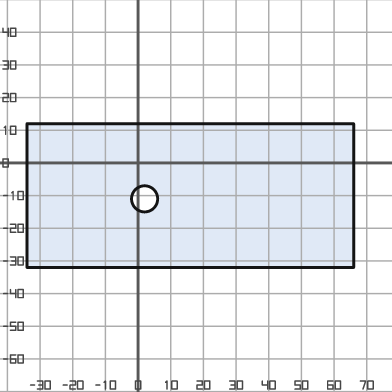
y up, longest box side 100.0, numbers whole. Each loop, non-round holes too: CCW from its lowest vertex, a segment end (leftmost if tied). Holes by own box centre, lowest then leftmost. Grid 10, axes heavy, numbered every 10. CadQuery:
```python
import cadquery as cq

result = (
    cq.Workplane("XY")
    .moveTo(-34.0, -32.0)
    .lineTo(66.0, -32.0)
    .lineTo(66.0, 12.0)
    .lineTo(-34.0, 12.0)
    .close()
    .moveTo(2.0, -11.0)
    .circle(4.0)
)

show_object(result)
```